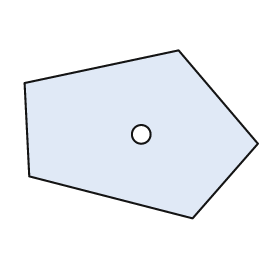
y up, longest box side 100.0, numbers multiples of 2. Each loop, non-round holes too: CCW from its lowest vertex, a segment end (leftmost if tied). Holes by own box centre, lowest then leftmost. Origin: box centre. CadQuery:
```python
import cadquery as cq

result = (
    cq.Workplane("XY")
    .moveTo(22.0, -36.0)
    .lineTo(50.0, -4.0)
    .lineTo(16.0, 36.0)
    .lineTo(-50.0, 22.0)
    .lineTo(-48.0, -18.0)
    .close()
    .moveTo(0.0, 0.0)
    .circle(4.0)
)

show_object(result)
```